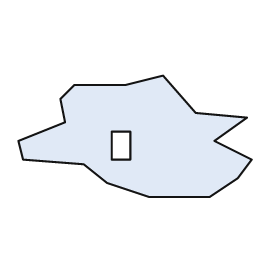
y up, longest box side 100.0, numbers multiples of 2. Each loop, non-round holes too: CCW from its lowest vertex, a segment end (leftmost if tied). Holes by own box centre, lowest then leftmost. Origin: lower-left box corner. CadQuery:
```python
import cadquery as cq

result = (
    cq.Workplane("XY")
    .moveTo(56.0, 0.0)
    .lineTo(82.0, 0.0)
    .lineTo(94.0, 8.0)
    .lineTo(100.0, 16.0)
    .lineTo(84.0, 24.0)
    .lineTo(98.0, 34.0)
    .lineTo(76.0, 36.0)
    .lineTo(62.0, 52.0)
    .lineTo(46.0, 48.0)
    .lineTo(24.0, 48.0)
    .lineTo(18.0, 42.0)
    .lineTo(20.0, 32.0)
    .lineTo(0.0, 24.0)
    .lineTo(2.0, 16.0)
    .lineTo(28.0, 14.0)
    .lineTo(38.0, 6.0)
    .close()
    .moveTo(40.0, 16.0)
    .lineTo(48.0, 16.0)
    .lineTo(48.0, 28.0)
    .lineTo(40.0, 28.0)
    .close()
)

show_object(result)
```